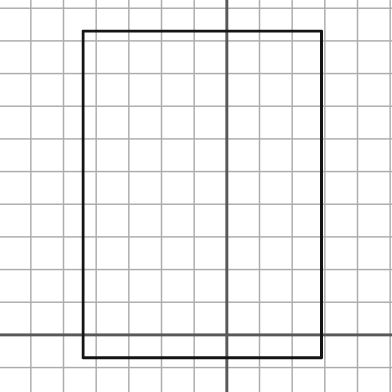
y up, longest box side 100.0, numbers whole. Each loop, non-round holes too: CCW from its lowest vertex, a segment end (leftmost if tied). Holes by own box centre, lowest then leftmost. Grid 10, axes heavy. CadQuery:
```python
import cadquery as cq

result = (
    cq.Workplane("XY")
    .moveTo(-44.0, -7.0)
    .lineTo(29.0, -7.0)
    .lineTo(29.0, 93.0)
    .lineTo(-44.0, 93.0)
    .close()
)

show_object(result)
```